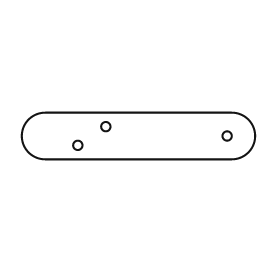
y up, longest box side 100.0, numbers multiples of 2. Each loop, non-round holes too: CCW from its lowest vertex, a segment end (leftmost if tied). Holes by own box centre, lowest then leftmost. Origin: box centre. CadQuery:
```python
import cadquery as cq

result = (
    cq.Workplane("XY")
    .moveTo(-40.0, -10.0)
    .lineTo(40.0, -10.0)
    .threePointArc((50.0, 0.0), (40.0, 10.0))
    .lineTo(-40.0, 10.0)
    .threePointArc((-50.0, 0.0), (-40.0, -10.0))
    .close()
    .moveTo(-26.0, -4.0)
    .circle(2.0)
    .moveTo(38.0, 0.0)
    .circle(2.0)
    .moveTo(-14.0, 4.0)
    .circle(2.0)
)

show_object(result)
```